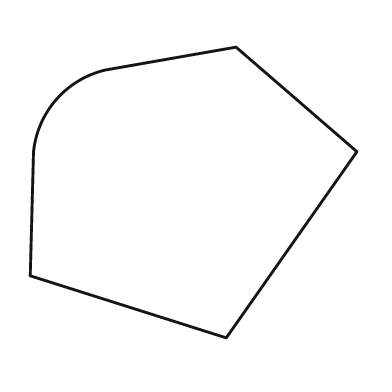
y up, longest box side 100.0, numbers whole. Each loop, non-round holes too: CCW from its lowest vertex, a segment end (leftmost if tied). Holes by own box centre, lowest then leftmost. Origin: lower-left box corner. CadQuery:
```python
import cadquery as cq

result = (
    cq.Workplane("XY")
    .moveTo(60.0, 0.0)
    .lineTo(100.0, 57.0)
    .lineTo(63.0, 89.0)
    .lineTo(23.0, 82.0)
    .threePointArc((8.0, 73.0), (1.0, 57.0))
    .lineTo(0.0, 19.0)
    .close()
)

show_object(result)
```